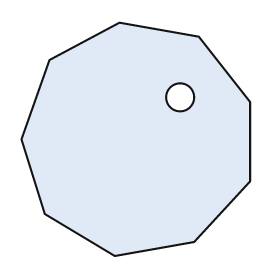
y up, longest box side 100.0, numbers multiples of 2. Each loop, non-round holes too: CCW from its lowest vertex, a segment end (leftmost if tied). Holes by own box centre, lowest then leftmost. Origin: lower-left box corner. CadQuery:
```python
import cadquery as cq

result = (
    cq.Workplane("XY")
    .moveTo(40.0, 0.0)
    .lineTo(74.0, 6.0)
    .lineTo(98.0, 32.0)
    .lineTo(98.0, 66.0)
    .lineTo(76.0, 94.0)
    .lineTo(42.0, 100.0)
    .lineTo(12.0, 84.0)
    .lineTo(0.0, 50.0)
    .lineTo(10.0, 18.0)
    .close()
    .moveTo(68.0, 68.0)
    .circle(6.0)
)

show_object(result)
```